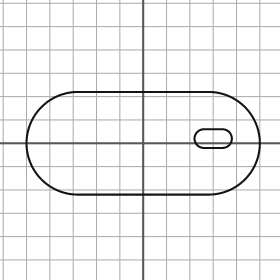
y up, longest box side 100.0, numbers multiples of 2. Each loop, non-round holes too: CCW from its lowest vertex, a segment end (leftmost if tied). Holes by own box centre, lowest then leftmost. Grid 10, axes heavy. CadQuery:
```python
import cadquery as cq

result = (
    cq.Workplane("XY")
    .moveTo(-28.0, -22.0)
    .lineTo(28.0, -22.0)
    .threePointArc((50.0, 0.0), (28.0, 22.0))
    .lineTo(-28.0, 22.0)
    .threePointArc((-50.0, 0.0), (-28.0, -22.0))
    .close()
    .moveTo(26.0, -2.0)
    .lineTo(34.0, -2.0)
    .threePointArc((38.0, 2.0), (34.0, 6.0))
    .lineTo(26.0, 6.0)
    .threePointArc((22.0, 2.0), (26.0, -2.0))
    .close()
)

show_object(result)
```